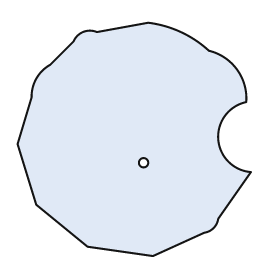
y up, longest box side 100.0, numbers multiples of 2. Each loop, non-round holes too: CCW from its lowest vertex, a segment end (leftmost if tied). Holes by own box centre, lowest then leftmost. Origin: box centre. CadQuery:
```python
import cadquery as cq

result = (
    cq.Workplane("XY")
    .moveTo(8.0, -50.0)
    .lineTo(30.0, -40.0)
    .threePointArc((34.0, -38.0), (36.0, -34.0))
    .lineTo(50.0, -14.0)
    .threePointArc((36.0, 0.0), (48.0, 16.0))
    .threePointArc((44.0, 30.0), (32.0, 38.0))
    .threePointArc((20.0, 46.0), (6.0, 50.0))
    .lineTo(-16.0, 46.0)
    .threePointArc((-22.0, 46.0), (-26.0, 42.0))
    .lineTo(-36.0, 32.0)
    .threePointArc((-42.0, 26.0), (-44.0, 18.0))
    .lineTo(-50.0, -2.0)
    .lineTo(-42.0, -28.0)
    .lineTo(-20.0, -46.0)
    .close()
    .moveTo(4.0, -10.0)
    .circle(2.0)
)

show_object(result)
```